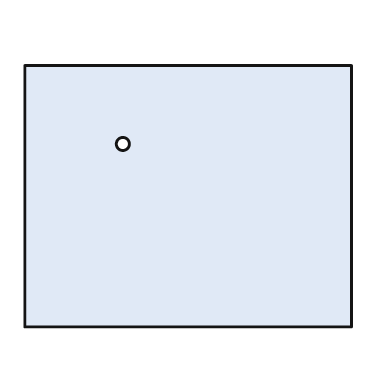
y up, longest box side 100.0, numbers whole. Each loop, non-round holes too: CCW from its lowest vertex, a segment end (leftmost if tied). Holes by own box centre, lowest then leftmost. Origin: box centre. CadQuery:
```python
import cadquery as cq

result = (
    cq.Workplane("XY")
    .moveTo(-50.0, -40.0)
    .lineTo(50.0, -40.0)
    .lineTo(50.0, 40.0)
    .lineTo(-50.0, 40.0)
    .close()
    .moveTo(-20.0, 16.0)
    .circle(2.0)
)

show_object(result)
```